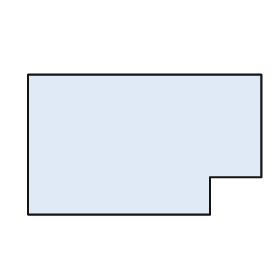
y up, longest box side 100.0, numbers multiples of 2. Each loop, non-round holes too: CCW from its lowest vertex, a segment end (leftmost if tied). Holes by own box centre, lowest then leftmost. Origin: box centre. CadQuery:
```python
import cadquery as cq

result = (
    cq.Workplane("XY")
    .moveTo(-50.0, -30.0)
    .lineTo(28.0, -30.0)
    .lineTo(28.0, -14.0)
    .lineTo(50.0, -14.0)
    .lineTo(50.0, 30.0)
    .lineTo(-50.0, 30.0)
    .close()
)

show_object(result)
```